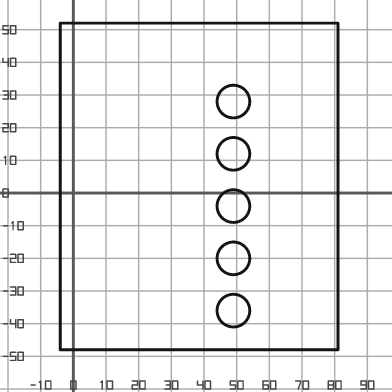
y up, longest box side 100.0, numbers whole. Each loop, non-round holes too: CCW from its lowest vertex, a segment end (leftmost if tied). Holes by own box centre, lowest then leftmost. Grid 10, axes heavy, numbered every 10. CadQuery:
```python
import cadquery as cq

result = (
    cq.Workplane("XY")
    .moveTo(-4.0, -48.0)
    .lineTo(81.0, -48.0)
    .lineTo(81.0, 52.0)
    .lineTo(-4.0, 52.0)
    .close()
    .moveTo(49.0, -36.0)
    .circle(5.0)
    .moveTo(49.0, -20.0)
    .circle(5.0)
    .moveTo(49.0, -4.0)
    .circle(5.0)
    .moveTo(49.0, 12.0)
    .circle(5.0)
    .moveTo(49.0, 28.0)
    .circle(5.0)
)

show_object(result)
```